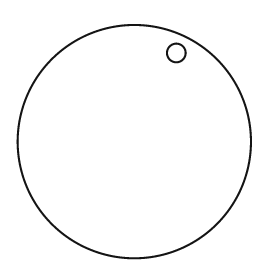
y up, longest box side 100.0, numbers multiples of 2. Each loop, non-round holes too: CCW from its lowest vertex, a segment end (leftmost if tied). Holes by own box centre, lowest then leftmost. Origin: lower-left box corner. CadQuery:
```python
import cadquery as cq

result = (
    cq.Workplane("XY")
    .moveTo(50.0, 50.0)
    .circle(50.0)
    .moveTo(68.0, 88.0)
    .circle(4.0)
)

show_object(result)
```